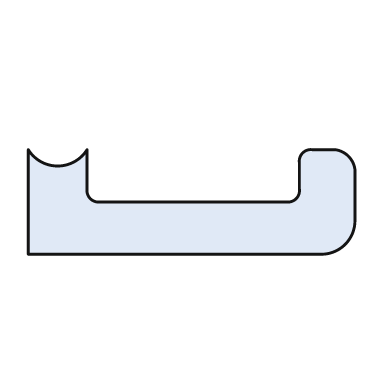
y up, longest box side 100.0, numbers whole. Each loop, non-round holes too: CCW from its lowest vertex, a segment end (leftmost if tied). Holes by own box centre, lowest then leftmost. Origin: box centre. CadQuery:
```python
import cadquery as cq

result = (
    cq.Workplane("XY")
    .moveTo(-50.0, -16.0)
    .lineTo(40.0, -16.0)
    .threePointArc((47.0, -13.0), (50.0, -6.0))
    .lineTo(50.0, 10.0)
    .threePointArc((48.0, 14.0), (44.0, 16.0))
    .lineTo(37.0, 16.0)
    .threePointArc((34.0, 15.0), (33.0, 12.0))
    .lineTo(33.0, 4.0)
    .threePointArc((32.0, 1.0), (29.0, 0.0))
    .lineTo(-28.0, 0.0)
    .threePointArc((-31.0, 1.0), (-32.0, 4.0))
    .lineTo(-32.0, 16.0)
    .threePointArc((-41.0, 11.0), (-50.0, 16.0))
    .close()
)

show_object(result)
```